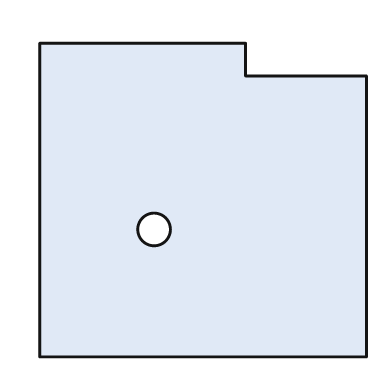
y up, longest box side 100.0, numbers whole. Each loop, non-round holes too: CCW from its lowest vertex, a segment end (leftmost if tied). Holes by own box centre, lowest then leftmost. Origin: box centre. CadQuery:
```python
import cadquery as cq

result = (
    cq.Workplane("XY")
    .moveTo(-50.0, -48.0)
    .lineTo(50.0, -48.0)
    .lineTo(50.0, 38.0)
    .lineTo(13.0, 38.0)
    .lineTo(13.0, 48.0)
    .lineTo(-50.0, 48.0)
    .close()
    .moveTo(-15.0, -9.0)
    .circle(5.0)
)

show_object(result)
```